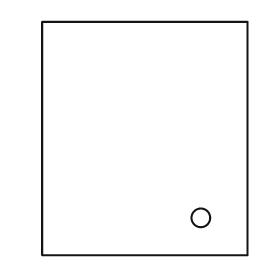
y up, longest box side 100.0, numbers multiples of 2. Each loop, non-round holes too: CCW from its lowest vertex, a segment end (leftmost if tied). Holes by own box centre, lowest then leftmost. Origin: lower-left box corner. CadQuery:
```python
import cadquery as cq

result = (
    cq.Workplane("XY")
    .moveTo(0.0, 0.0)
    .lineTo(88.0, 0.0)
    .lineTo(88.0, 100.0)
    .lineTo(0.0, 100.0)
    .close()
    .moveTo(68.0, 16.0)
    .circle(4.0)
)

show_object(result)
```